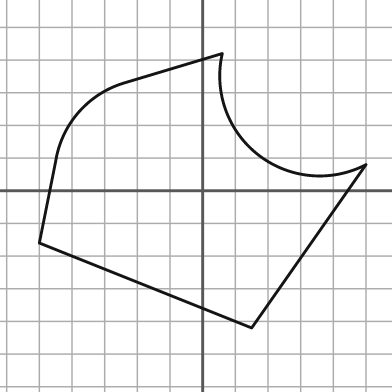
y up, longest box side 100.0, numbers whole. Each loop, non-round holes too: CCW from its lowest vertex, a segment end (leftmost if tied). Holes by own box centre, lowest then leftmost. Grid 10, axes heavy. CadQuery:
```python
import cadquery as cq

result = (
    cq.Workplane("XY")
    .moveTo(15.0, -42.0)
    .lineTo(50.0, 8.0)
    .threePointArc((17.0, 11.0), (6.0, 42.0))
    .lineTo(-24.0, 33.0)
    .threePointArc((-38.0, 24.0), (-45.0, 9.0))
    .lineTo(-50.0, -16.0)
    .close()
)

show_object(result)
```